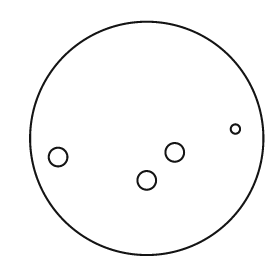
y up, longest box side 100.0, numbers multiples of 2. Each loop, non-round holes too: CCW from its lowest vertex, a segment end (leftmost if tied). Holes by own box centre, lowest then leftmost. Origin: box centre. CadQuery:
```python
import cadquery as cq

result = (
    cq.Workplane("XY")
    .moveTo(0.0, 0.0)
    .circle(50.0)
    .moveTo(0.0, -18.0)
    .circle(4.0)
    .moveTo(-38.0, -8.0)
    .circle(4.0)
    .moveTo(12.0, -6.0)
    .circle(4.0)
    .moveTo(38.0, 4.0)
    .circle(2.0)
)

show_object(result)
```